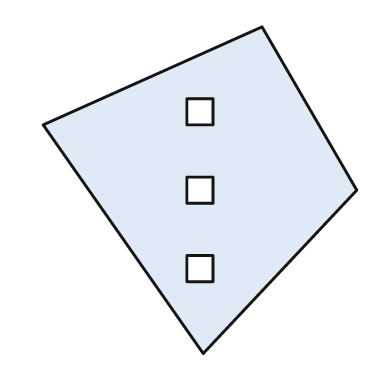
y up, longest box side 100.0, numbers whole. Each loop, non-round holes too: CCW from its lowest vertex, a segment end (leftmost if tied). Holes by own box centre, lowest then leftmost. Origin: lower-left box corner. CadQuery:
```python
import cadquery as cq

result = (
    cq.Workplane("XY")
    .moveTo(49.0, 0.0)
    .lineTo(96.0, 50.0)
    .lineTo(67.0, 100.0)
    .lineTo(0.0, 70.0)
    .close()
    .moveTo(44.0, 22.0)
    .lineTo(52.0, 22.0)
    .lineTo(52.0, 30.0)
    .lineTo(44.0, 30.0)
    .close()
    .moveTo(44.0, 46.0)
    .lineTo(52.0, 46.0)
    .lineTo(52.0, 54.0)
    .lineTo(44.0, 54.0)
    .close()
    .moveTo(44.0, 70.0)
    .lineTo(52.0, 70.0)
    .lineTo(52.0, 78.0)
    .lineTo(44.0, 78.0)
    .close()
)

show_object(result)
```